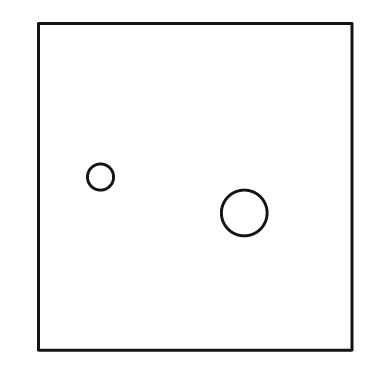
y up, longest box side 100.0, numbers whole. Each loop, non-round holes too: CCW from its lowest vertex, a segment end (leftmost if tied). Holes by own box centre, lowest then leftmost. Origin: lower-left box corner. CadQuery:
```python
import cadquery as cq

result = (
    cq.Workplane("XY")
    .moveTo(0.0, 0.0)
    .lineTo(96.0, 0.0)
    .lineTo(96.0, 100.0)
    .lineTo(0.0, 100.0)
    .close()
    .moveTo(63.0, 42.0)
    .circle(7.0)
    .moveTo(19.0, 53.0)
    .circle(4.0)
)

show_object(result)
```